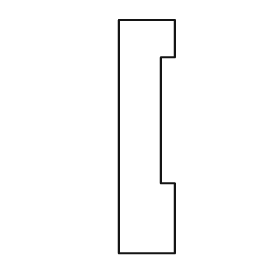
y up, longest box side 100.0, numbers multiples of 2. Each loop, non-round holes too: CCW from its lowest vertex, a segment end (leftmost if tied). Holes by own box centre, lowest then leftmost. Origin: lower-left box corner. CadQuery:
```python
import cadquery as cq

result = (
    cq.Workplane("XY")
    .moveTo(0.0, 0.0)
    .lineTo(24.0, 0.0)
    .lineTo(24.0, 30.0)
    .lineTo(18.0, 30.0)
    .lineTo(18.0, 84.0)
    .lineTo(24.0, 84.0)
    .lineTo(24.0, 100.0)
    .lineTo(0.0, 100.0)
    .close()
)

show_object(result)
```